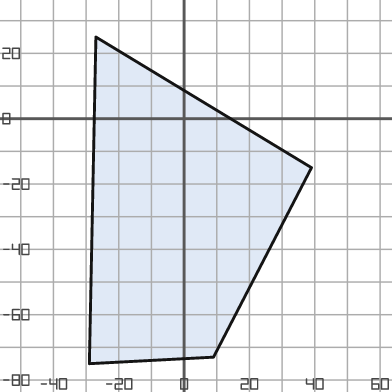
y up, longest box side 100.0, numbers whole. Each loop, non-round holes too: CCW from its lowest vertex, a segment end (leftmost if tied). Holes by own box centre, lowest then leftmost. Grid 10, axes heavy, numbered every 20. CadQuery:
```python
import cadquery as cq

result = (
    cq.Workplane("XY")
    .moveTo(-29.0, -75.0)
    .lineTo(9.0, -73.0)
    .lineTo(39.0, -15.0)
    .lineTo(-27.0, 25.0)
    .close()
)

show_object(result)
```